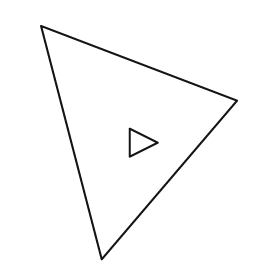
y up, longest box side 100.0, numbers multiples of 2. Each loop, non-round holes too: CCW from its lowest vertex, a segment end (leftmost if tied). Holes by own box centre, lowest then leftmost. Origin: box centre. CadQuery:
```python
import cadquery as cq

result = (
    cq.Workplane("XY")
    .moveTo(-16.0, -50.0)
    .lineTo(42.0, 18.0)
    .lineTo(-42.0, 50.0)
    .close()
    .moveTo(-4.0, -6.0)
    .lineTo(8.0, 0.0)
    .lineTo(-4.0, 6.0)
    .close()
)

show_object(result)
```